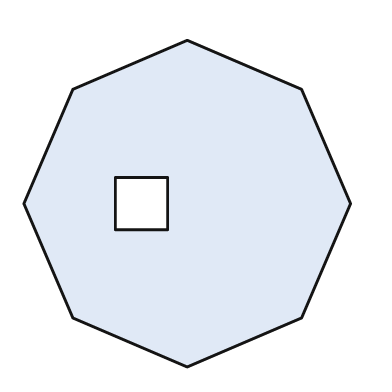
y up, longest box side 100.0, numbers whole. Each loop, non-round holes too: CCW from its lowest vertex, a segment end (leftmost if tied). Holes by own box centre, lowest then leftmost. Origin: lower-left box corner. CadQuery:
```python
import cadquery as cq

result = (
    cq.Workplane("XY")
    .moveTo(50.0, 0.0)
    .lineTo(85.0, 15.0)
    .lineTo(100.0, 50.0)
    .lineTo(85.0, 85.0)
    .lineTo(50.0, 100.0)
    .lineTo(15.0, 85.0)
    .lineTo(0.0, 50.0)
    .lineTo(15.0, 15.0)
    .close()
    .moveTo(28.0, 42.0)
    .lineTo(44.0, 42.0)
    .lineTo(44.0, 58.0)
    .lineTo(28.0, 58.0)
    .close()
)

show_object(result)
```